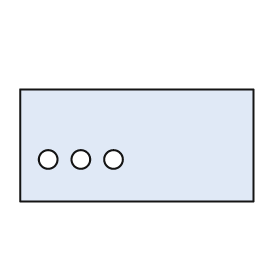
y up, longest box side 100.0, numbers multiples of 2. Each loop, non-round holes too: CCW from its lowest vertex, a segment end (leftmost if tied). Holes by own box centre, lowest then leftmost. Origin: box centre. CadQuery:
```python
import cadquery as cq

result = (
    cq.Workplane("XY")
    .moveTo(-50.0, -24.0)
    .lineTo(50.0, -24.0)
    .lineTo(50.0, 24.0)
    .lineTo(-50.0, 24.0)
    .close()
    .moveTo(-38.0, -6.0)
    .circle(4.0)
    .moveTo(-24.0, -6.0)
    .circle(4.0)
    .moveTo(-10.0, -6.0)
    .circle(4.0)
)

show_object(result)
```